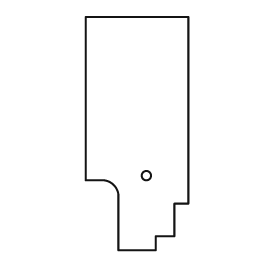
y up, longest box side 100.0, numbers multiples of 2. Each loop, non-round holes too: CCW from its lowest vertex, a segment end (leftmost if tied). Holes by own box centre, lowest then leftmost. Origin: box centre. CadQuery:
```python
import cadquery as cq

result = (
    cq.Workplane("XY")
    .moveTo(-8.0, -50.0)
    .lineTo(8.0, -50.0)
    .lineTo(8.0, -44.0)
    .lineTo(16.0, -44.0)
    .lineTo(16.0, -30.0)
    .lineTo(22.0, -30.0)
    .lineTo(22.0, 50.0)
    .lineTo(-22.0, 50.0)
    .lineTo(-22.0, -20.0)
    .lineTo(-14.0, -20.0)
    .threePointArc((-10.0, -22.0), (-8.0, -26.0))
    .close()
    .moveTo(4.0, -18.0)
    .circle(2.0)
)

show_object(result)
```